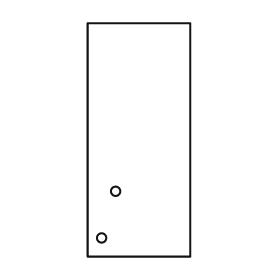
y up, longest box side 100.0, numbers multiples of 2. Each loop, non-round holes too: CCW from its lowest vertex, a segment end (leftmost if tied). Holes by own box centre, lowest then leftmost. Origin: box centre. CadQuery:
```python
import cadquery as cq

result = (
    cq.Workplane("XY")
    .moveTo(-22.0, -50.0)
    .lineTo(22.0, -50.0)
    .lineTo(22.0, 50.0)
    .lineTo(-22.0, 50.0)
    .close()
    .moveTo(-16.0, -42.0)
    .circle(2.0)
    .moveTo(-10.0, -22.0)
    .circle(2.0)
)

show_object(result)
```